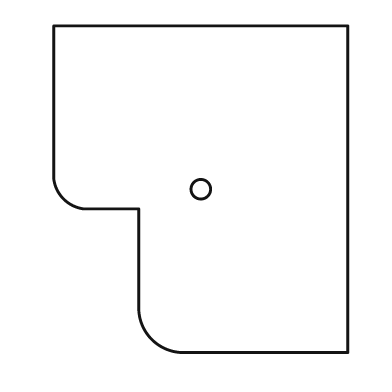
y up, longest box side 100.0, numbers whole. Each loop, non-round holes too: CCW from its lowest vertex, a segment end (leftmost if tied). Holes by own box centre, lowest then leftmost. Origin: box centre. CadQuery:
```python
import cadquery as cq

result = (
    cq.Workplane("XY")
    .moveTo(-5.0, -50.0)
    .lineTo(45.0, -50.0)
    .lineTo(45.0, 50.0)
    .lineTo(-45.0, 50.0)
    .lineTo(-45.0, 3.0)
    .threePointArc((-42.0, -3.0), (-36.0, -6.0))
    .lineTo(-19.0, -6.0)
    .lineTo(-19.0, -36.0)
    .threePointArc((-15.0, -46.0), (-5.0, -50.0))
    .close()
    .moveTo(0.0, 0.0)
    .circle(3.0)
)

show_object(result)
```